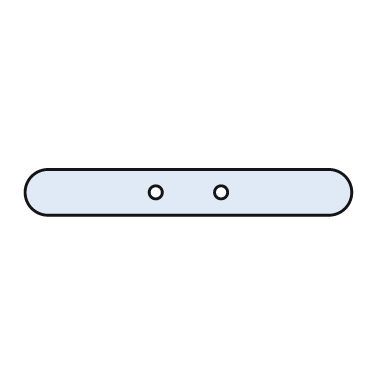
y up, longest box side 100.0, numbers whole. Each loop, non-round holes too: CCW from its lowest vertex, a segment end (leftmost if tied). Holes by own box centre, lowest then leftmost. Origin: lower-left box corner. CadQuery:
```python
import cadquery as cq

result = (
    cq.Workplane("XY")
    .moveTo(7.0, 0.0)
    .lineTo(93.0, 0.0)
    .threePointArc((100.0, 7.0), (93.0, 14.0))
    .lineTo(7.0, 14.0)
    .threePointArc((0.0, 7.0), (7.0, 0.0))
    .close()
    .moveTo(40.0, 7.0)
    .circle(2.0)
    .moveTo(60.0, 7.0)
    .circle(2.0)
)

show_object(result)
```